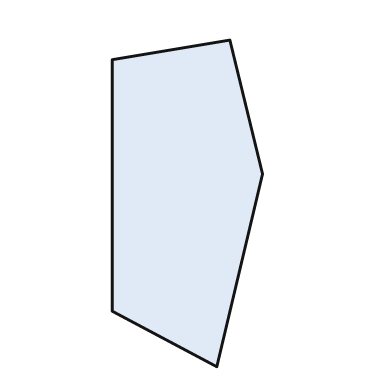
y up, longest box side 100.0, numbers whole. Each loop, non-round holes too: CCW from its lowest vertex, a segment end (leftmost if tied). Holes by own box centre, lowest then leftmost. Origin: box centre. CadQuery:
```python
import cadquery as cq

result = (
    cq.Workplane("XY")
    .moveTo(9.0, -50.0)
    .lineTo(23.0, 9.0)
    .lineTo(13.0, 50.0)
    .lineTo(-23.0, 44.0)
    .lineTo(-23.0, -33.0)
    .close()
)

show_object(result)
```